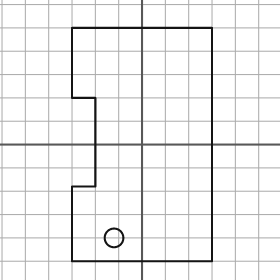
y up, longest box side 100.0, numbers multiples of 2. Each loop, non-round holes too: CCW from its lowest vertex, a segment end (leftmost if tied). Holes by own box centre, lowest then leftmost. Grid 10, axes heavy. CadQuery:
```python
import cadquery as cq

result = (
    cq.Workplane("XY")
    .moveTo(-30.0, -50.0)
    .lineTo(30.0, -50.0)
    .lineTo(30.0, 50.0)
    .lineTo(-30.0, 50.0)
    .lineTo(-30.0, 20.0)
    .lineTo(-20.0, 20.0)
    .lineTo(-20.0, -18.0)
    .lineTo(-30.0, -18.0)
    .close()
    .moveTo(-12.0, -40.0)
    .circle(4.0)
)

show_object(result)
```